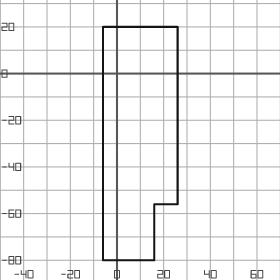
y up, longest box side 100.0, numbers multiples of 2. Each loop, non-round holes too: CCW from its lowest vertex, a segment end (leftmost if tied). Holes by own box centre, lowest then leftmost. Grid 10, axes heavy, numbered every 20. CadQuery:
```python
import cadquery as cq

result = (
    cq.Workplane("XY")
    .moveTo(-6.0, -80.0)
    .lineTo(16.0, -80.0)
    .lineTo(16.0, -56.0)
    .lineTo(26.0, -56.0)
    .lineTo(26.0, 20.0)
    .lineTo(-6.0, 20.0)
    .close()
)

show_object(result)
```